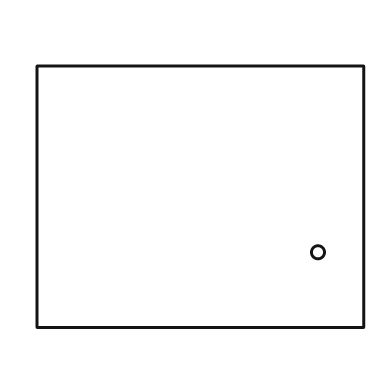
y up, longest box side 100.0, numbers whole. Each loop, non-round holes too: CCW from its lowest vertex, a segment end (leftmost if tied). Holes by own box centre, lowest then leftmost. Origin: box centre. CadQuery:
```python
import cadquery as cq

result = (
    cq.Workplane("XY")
    .moveTo(-50.0, -40.0)
    .lineTo(50.0, -40.0)
    .lineTo(50.0, 40.0)
    .lineTo(-50.0, 40.0)
    .close()
    .moveTo(36.0, -17.0)
    .circle(2.0)
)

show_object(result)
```